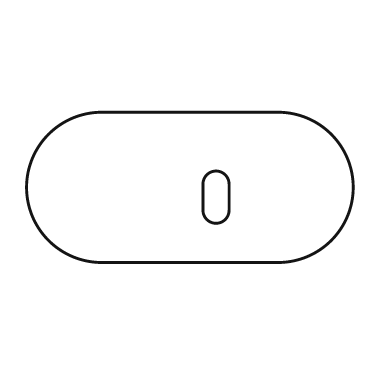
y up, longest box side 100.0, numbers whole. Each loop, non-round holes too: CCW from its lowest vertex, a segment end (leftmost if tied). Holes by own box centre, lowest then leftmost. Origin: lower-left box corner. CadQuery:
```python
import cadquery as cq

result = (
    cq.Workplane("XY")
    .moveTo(23.0, 0.0)
    .lineTo(77.0, 0.0)
    .threePointArc((100.0, 23.0), (77.0, 46.0))
    .lineTo(23.0, 46.0)
    .threePointArc((0.0, 23.0), (23.0, 0.0))
    .close()
    .moveTo(54.0, 16.0)
    .threePointArc((58.0, 12.0), (62.0, 16.0))
    .lineTo(62.0, 24.0)
    .threePointArc((58.0, 28.0), (54.0, 24.0))
    .close()
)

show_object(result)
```